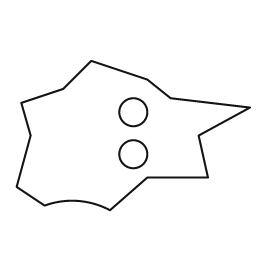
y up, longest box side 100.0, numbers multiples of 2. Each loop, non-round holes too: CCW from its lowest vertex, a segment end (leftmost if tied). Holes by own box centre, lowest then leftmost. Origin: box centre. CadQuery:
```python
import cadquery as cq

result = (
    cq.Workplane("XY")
    .moveTo(-10.0, -32.0)
    .lineTo(6.0, -18.0)
    .lineTo(32.0, -18.0)
    .lineTo(28.0, 0.0)
    .lineTo(50.0, 12.0)
    .lineTo(16.0, 16.0)
    .lineTo(6.0, 24.0)
    .lineTo(-18.0, 32.0)
    .lineTo(-30.0, 20.0)
    .lineTo(-48.0, 14.0)
    .lineTo(-44.0, 0.0)
    .lineTo(-50.0, -22.0)
    .lineTo(-38.0, -30.0)
    .threePointArc((-24.0, -28.0), (-10.0, -32.0))
    .close()
    .moveTo(0.0, -8.0)
    .circle(6.0)
    .moveTo(0.0, 10.0)
    .circle(6.0)
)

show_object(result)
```